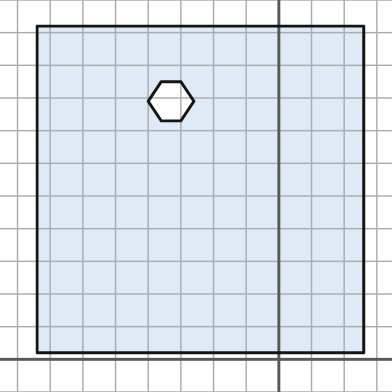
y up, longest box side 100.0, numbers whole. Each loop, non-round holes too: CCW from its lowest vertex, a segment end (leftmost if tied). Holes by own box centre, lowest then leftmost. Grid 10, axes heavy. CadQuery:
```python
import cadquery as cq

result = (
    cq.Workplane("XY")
    .moveTo(-74.0, 2.0)
    .lineTo(26.0, 2.0)
    .lineTo(26.0, 102.0)
    .lineTo(-74.0, 102.0)
    .close()
    .moveTo(-36.0, 73.0)
    .lineTo(-30.0, 73.0)
    .lineTo(-26.0, 79.0)
    .lineTo(-30.0, 85.0)
    .lineTo(-36.0, 85.0)
    .lineTo(-40.0, 79.0)
    .close()
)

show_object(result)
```